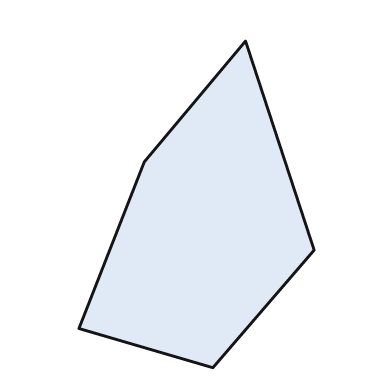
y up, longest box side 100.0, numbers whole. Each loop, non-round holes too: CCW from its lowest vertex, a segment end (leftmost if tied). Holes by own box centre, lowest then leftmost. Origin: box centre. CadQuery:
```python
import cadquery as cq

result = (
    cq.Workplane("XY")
    .moveTo(5.0, -50.0)
    .lineTo(36.0, -14.0)
    .lineTo(15.0, 50.0)
    .lineTo(-16.0, 13.0)
    .lineTo(-36.0, -38.0)
    .close()
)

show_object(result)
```